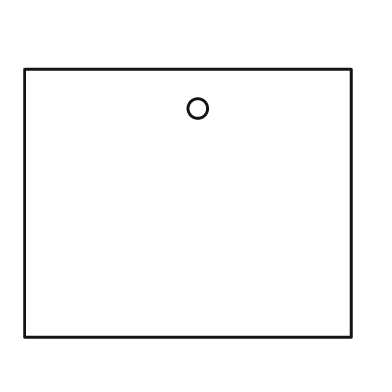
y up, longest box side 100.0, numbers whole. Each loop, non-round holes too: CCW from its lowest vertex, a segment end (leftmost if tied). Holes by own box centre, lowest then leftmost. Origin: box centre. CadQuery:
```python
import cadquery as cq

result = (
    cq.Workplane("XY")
    .moveTo(-50.0, -41.0)
    .lineTo(50.0, -41.0)
    .lineTo(50.0, 41.0)
    .lineTo(-50.0, 41.0)
    .close()
    .moveTo(3.0, 29.0)
    .circle(3.0)
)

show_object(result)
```